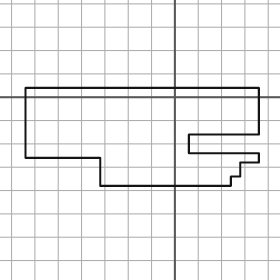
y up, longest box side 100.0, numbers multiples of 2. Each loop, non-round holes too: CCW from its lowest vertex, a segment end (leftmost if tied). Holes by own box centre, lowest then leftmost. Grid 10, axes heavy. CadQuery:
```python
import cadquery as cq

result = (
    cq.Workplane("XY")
    .moveTo(-32.0, -38.0)
    .lineTo(24.0, -38.0)
    .lineTo(24.0, -34.0)
    .lineTo(28.0, -34.0)
    .lineTo(28.0, -28.0)
    .lineTo(36.0, -28.0)
    .lineTo(36.0, -24.0)
    .lineTo(6.0, -24.0)
    .lineTo(6.0, -16.0)
    .lineTo(36.0, -16.0)
    .lineTo(36.0, 4.0)
    .lineTo(-64.0, 4.0)
    .lineTo(-64.0, -26.0)
    .lineTo(-32.0, -26.0)
    .close()
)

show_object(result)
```